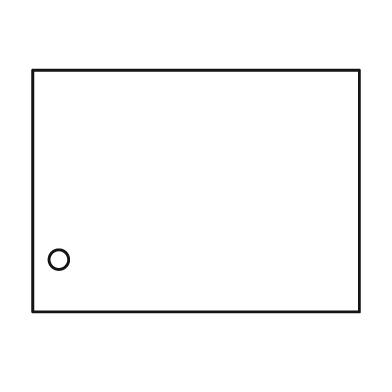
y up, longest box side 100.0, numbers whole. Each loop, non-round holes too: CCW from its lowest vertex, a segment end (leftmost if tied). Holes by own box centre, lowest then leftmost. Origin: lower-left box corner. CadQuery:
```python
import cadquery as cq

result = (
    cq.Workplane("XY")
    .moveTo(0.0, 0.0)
    .lineTo(100.0, 0.0)
    .lineTo(100.0, 74.0)
    .lineTo(0.0, 74.0)
    .close()
    .moveTo(8.0, 16.0)
    .circle(3.0)
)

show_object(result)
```